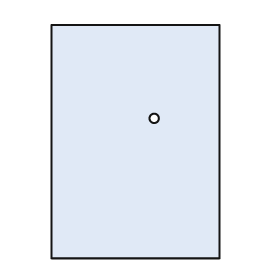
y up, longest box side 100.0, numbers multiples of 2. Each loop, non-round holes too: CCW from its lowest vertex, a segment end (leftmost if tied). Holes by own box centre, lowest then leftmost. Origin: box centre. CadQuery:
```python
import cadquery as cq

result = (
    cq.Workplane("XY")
    .moveTo(-36.0, -50.0)
    .lineTo(36.0, -50.0)
    .lineTo(36.0, 50.0)
    .lineTo(-36.0, 50.0)
    .close()
    .moveTo(8.0, 10.0)
    .circle(2.0)
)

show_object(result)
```